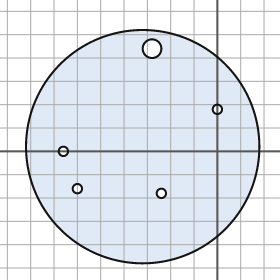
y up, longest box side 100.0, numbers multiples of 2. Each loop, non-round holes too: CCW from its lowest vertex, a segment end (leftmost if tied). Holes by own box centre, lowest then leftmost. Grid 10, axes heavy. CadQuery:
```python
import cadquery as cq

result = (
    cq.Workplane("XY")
    .moveTo(-32.0, 2.0)
    .circle(50.0)
    .moveTo(-24.0, -18.0)
    .circle(2.0)
    .moveTo(-60.0, -16.0)
    .circle(2.0)
    .moveTo(-66.0, 0.0)
    .circle(2.0)
    .moveTo(0.0, 18.0)
    .circle(2.0)
    .moveTo(-28.0, 44.0)
    .circle(4.0)
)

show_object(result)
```